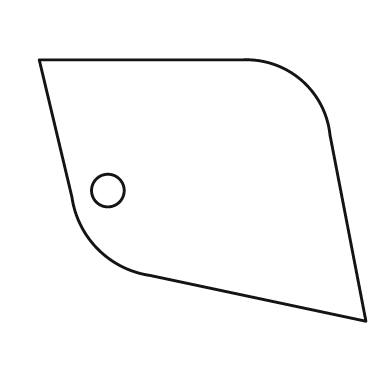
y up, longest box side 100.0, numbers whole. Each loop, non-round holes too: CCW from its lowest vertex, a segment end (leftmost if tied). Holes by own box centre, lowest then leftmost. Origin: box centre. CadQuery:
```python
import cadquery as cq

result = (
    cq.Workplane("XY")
    .moveTo(50.0, -40.0)
    .lineTo(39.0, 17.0)
    .threePointArc((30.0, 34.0), (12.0, 40.0))
    .lineTo(-50.0, 40.0)
    .lineTo(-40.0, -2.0)
    .threePointArc((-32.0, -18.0), (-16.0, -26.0))
    .close()
    .moveTo(-29.0, 0.0)
    .circle(5.0)
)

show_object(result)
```